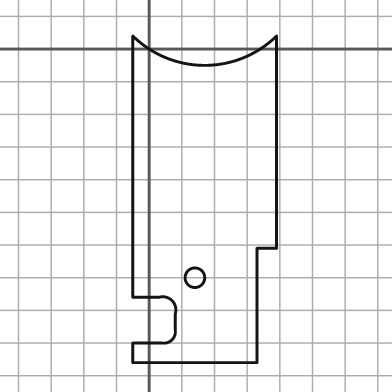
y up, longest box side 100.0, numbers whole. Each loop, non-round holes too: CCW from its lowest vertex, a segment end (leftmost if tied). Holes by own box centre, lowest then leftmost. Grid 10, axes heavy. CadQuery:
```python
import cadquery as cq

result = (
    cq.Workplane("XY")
    .moveTo(-5.0, -96.0)
    .lineTo(33.0, -96.0)
    .lineTo(33.0, -61.0)
    .lineTo(39.0, -61.0)
    .lineTo(39.0, 4.0)
    .threePointArc((17.0, -5.0), (-5.0, 4.0))
    .lineTo(-5.0, -76.0)
    .lineTo(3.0, -76.0)
    .threePointArc((7.0, -77.0), (8.0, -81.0))
    .lineTo(8.0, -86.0)
    .threePointArc((7.0, -89.0), (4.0, -90.0))
    .lineTo(-5.0, -90.0)
    .close()
    .moveTo(14.0, -70.0)
    .circle(3.0)
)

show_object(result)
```